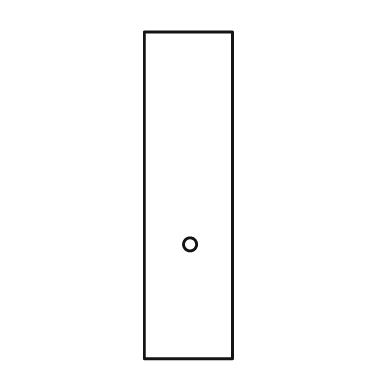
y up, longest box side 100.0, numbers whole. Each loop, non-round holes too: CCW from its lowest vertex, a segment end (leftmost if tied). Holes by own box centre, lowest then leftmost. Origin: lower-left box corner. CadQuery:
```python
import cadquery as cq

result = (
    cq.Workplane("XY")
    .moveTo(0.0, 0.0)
    .lineTo(27.0, 0.0)
    .lineTo(27.0, 100.0)
    .lineTo(0.0, 100.0)
    .close()
    .moveTo(14.0, 35.0)
    .circle(2.0)
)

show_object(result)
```